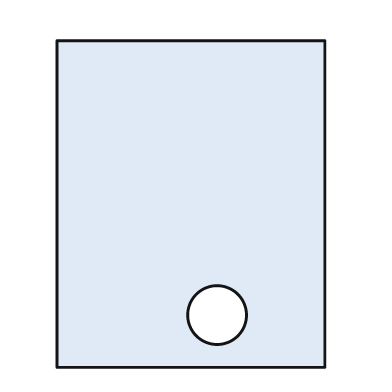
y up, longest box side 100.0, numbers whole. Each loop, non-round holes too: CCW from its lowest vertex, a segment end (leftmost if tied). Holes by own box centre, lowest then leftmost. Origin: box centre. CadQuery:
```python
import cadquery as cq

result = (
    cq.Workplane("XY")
    .moveTo(-41.0, -50.0)
    .lineTo(41.0, -50.0)
    .lineTo(41.0, 50.0)
    .lineTo(-41.0, 50.0)
    .close()
    .moveTo(8.0, -34.0)
    .circle(9.0)
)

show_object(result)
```